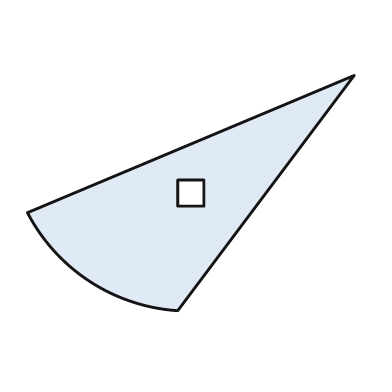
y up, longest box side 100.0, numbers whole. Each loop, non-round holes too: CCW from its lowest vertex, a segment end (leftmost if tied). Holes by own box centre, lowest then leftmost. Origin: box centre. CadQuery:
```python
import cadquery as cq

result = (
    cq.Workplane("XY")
    .moveTo(-4.0, -36.0)
    .lineTo(50.0, 36.0)
    .lineTo(-50.0, -6.0)
    .threePointArc((-31.0, -27.0), (-4.0, -36.0))
    .close()
    .moveTo(-4.0, -4.0)
    .lineTo(4.0, -4.0)
    .lineTo(4.0, 4.0)
    .lineTo(-4.0, 4.0)
    .close()
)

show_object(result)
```